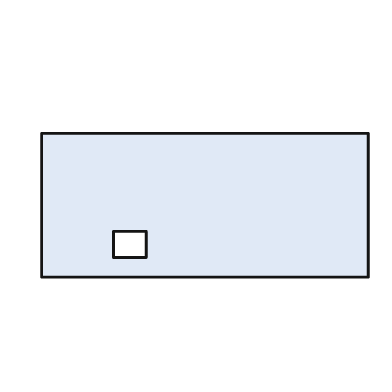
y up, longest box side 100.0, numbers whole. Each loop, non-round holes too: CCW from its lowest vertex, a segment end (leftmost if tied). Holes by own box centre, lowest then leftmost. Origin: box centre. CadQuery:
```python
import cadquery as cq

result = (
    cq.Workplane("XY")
    .moveTo(-50.0, -22.0)
    .lineTo(50.0, -22.0)
    .lineTo(50.0, 22.0)
    .lineTo(-50.0, 22.0)
    .close()
    .moveTo(-28.0, -16.0)
    .lineTo(-18.0, -16.0)
    .lineTo(-18.0, -8.0)
    .lineTo(-28.0, -8.0)
    .close()
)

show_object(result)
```